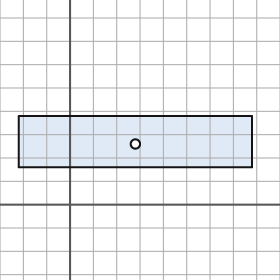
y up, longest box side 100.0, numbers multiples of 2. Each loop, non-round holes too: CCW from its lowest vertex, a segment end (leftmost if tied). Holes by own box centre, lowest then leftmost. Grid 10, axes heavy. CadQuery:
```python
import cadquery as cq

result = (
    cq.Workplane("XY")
    .moveTo(-22.0, 16.0)
    .lineTo(78.0, 16.0)
    .lineTo(78.0, 38.0)
    .lineTo(-22.0, 38.0)
    .close()
    .moveTo(28.0, 26.0)
    .circle(2.0)
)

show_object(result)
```